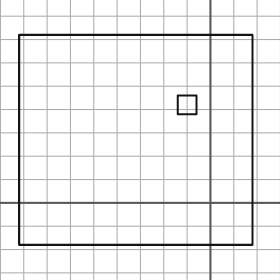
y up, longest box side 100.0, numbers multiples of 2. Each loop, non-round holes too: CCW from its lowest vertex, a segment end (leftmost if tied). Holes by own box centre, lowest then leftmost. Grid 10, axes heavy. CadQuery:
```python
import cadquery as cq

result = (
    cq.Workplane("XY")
    .moveTo(-82.0, -18.0)
    .lineTo(18.0, -18.0)
    .lineTo(18.0, 72.0)
    .lineTo(-82.0, 72.0)
    .close()
    .moveTo(-14.0, 38.0)
    .lineTo(-6.0, 38.0)
    .lineTo(-6.0, 46.0)
    .lineTo(-14.0, 46.0)
    .close()
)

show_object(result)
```